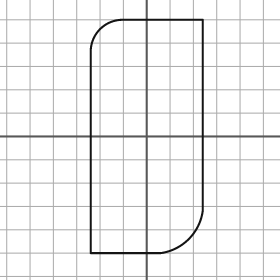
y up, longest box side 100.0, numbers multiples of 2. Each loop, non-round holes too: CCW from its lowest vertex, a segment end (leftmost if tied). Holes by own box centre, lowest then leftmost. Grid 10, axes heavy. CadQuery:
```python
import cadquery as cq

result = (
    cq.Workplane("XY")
    .moveTo(-24.0, -50.0)
    .lineTo(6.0, -50.0)
    .threePointArc((18.0, -44.0), (24.0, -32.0))
    .lineTo(24.0, 50.0)
    .lineTo(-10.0, 50.0)
    .threePointArc((-20.0, 46.0), (-24.0, 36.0))
    .close()
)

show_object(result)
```